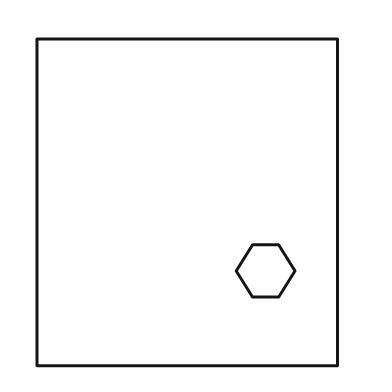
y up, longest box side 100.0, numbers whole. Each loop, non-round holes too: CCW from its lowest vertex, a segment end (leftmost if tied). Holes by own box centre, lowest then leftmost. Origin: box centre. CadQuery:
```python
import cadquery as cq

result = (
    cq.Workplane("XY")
    .moveTo(-46.0, -50.0)
    .lineTo(46.0, -50.0)
    .lineTo(46.0, 50.0)
    .lineTo(-46.0, 50.0)
    .close()
    .moveTo(20.0, -29.0)
    .lineTo(28.0, -29.0)
    .lineTo(33.0, -21.0)
    .lineTo(28.0, -13.0)
    .lineTo(20.0, -13.0)
    .lineTo(15.0, -21.0)
    .close()
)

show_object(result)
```